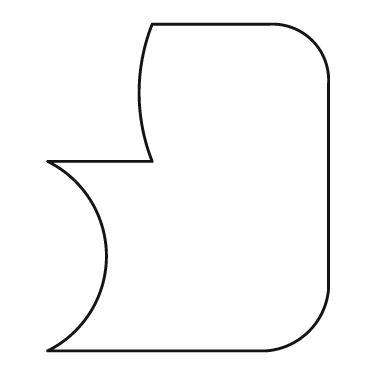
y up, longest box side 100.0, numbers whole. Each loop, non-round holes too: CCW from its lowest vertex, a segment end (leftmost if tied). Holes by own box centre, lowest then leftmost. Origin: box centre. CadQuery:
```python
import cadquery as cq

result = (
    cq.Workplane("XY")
    .moveTo(-43.0, -50.0)
    .lineTo(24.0, -50.0)
    .threePointArc((37.0, -44.0), (43.0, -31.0))
    .lineTo(43.0, 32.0)
    .threePointArc((38.0, 45.0), (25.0, 50.0))
    .lineTo(-11.0, 50.0)
    .threePointArc((-15.0, 29.0), (-11.0, 8.0))
    .lineTo(-43.0, 8.0)
    .threePointArc((-25.0, -21.0), (-43.0, -50.0))
    .close()
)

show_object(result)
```